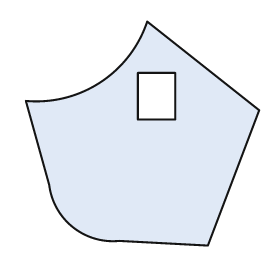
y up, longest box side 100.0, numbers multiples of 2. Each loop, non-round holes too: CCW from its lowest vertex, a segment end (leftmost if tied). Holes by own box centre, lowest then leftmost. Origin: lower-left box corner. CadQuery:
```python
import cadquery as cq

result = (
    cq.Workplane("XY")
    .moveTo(78.0, 0.0)
    .lineTo(100.0, 58.0)
    .lineTo(52.0, 96.0)
    .threePointArc((32.0, 70.0), (0.0, 62.0))
    .lineTo(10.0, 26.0)
    .threePointArc((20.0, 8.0), (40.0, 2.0))
    .close()
    .moveTo(48.0, 54.0)
    .lineTo(64.0, 54.0)
    .lineTo(64.0, 74.0)
    .lineTo(48.0, 74.0)
    .close()
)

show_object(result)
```